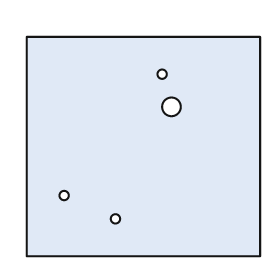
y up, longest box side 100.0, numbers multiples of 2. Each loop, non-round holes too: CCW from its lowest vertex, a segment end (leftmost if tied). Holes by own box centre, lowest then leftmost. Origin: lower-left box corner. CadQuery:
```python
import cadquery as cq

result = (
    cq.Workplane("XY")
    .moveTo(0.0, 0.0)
    .lineTo(100.0, 0.0)
    .lineTo(100.0, 94.0)
    .lineTo(0.0, 94.0)
    .close()
    .moveTo(38.0, 16.0)
    .circle(2.0)
    .moveTo(16.0, 26.0)
    .circle(2.0)
    .moveTo(62.0, 64.0)
    .circle(4.0)
    .moveTo(58.0, 78.0)
    .circle(2.0)
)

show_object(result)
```